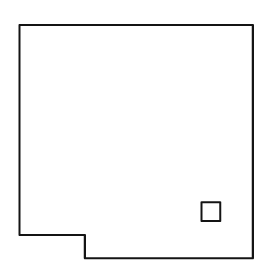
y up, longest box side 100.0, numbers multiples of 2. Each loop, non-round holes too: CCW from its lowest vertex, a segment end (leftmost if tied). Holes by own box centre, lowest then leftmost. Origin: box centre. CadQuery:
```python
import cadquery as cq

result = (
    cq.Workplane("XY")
    .moveTo(-22.0, -50.0)
    .lineTo(50.0, -50.0)
    .lineTo(50.0, 50.0)
    .lineTo(-50.0, 50.0)
    .lineTo(-50.0, -40.0)
    .lineTo(-22.0, -40.0)
    .close()
    .moveTo(28.0, -34.0)
    .lineTo(36.0, -34.0)
    .lineTo(36.0, -26.0)
    .lineTo(28.0, -26.0)
    .close()
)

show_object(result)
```